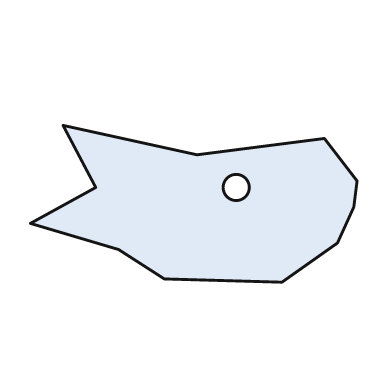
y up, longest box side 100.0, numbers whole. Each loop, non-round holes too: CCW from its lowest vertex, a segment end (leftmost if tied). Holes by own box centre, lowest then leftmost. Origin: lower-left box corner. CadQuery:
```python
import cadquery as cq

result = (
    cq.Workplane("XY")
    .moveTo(77.0, 0.0)
    .lineTo(94.0, 12.0)
    .lineTo(99.0, 23.0)
    .lineTo(100.0, 31.0)
    .lineTo(90.0, 44.0)
    .lineTo(51.0, 39.0)
    .lineTo(10.0, 48.0)
    .lineTo(20.0, 29.0)
    .lineTo(0.0, 18.0)
    .lineTo(27.0, 10.0)
    .lineTo(41.0, 1.0)
    .close()
    .moveTo(63.0, 29.0)
    .circle(4.0)
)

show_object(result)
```